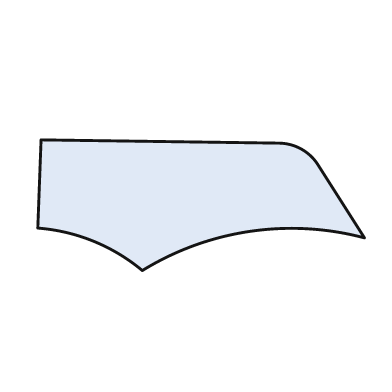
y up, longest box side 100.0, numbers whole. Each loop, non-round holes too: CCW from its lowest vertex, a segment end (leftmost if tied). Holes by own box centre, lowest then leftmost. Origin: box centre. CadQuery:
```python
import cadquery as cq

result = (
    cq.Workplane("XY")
    .moveTo(-18.0, -20.0)
    .threePointArc((15.0, -8.0), (50.0, -10.0))
    .lineTo(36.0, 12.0)
    .threePointArc((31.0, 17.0), (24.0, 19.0))
    .lineTo(-49.0, 20.0)
    .lineTo(-50.0, -7.0)
    .threePointArc((-33.0, -11.0), (-18.0, -20.0))
    .close()
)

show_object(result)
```